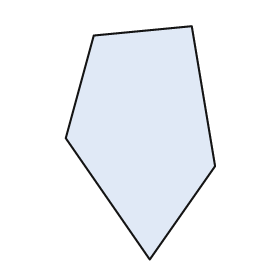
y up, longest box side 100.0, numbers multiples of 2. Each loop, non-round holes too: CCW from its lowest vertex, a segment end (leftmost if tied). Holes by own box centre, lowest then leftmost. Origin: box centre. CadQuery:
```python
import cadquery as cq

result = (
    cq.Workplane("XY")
    .moveTo(4.0, -50.0)
    .lineTo(32.0, -10.0)
    .lineTo(22.0, 50.0)
    .lineTo(-20.0, 46.0)
    .lineTo(-32.0, 2.0)
    .close()
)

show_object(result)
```